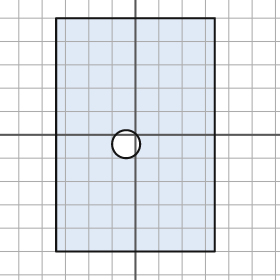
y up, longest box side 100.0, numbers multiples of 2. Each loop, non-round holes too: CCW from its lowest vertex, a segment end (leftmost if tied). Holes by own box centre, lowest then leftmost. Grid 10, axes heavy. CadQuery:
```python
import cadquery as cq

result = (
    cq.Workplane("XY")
    .moveTo(-34.0, -50.0)
    .lineTo(34.0, -50.0)
    .lineTo(34.0, 50.0)
    .lineTo(-34.0, 50.0)
    .close()
    .moveTo(-4.0, -4.0)
    .circle(6.0)
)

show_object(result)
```